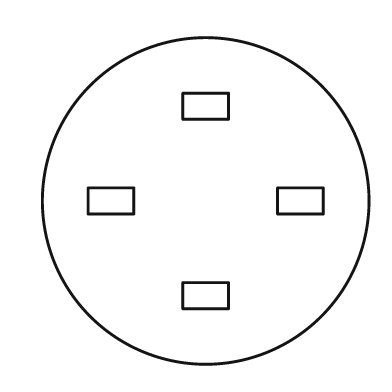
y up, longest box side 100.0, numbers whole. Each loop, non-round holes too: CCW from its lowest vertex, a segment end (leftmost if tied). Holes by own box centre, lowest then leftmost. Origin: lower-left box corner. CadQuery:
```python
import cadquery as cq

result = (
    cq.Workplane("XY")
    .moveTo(50.0, 50.0)
    .circle(50.0)
    .moveTo(43.0, 17.0)
    .lineTo(57.0, 17.0)
    .lineTo(57.0, 25.0)
    .lineTo(43.0, 25.0)
    .close()
    .moveTo(14.0, 46.0)
    .lineTo(28.0, 46.0)
    .lineTo(28.0, 54.0)
    .lineTo(14.0, 54.0)
    .close()
    .moveTo(72.0, 46.0)
    .lineTo(86.0, 46.0)
    .lineTo(86.0, 54.0)
    .lineTo(72.0, 54.0)
    .close()
    .moveTo(43.0, 75.0)
    .lineTo(57.0, 75.0)
    .lineTo(57.0, 83.0)
    .lineTo(43.0, 83.0)
    .close()
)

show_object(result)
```